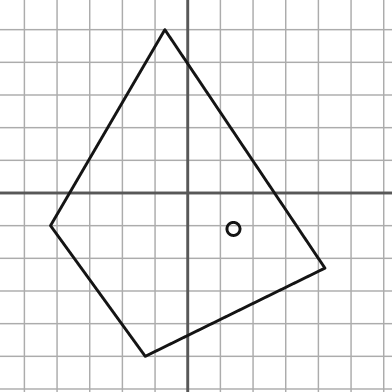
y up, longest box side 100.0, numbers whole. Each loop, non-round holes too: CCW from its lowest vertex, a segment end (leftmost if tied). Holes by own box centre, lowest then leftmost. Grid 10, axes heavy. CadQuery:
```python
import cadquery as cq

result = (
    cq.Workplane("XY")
    .moveTo(-13.0, -50.0)
    .lineTo(42.0, -23.0)
    .lineTo(-7.0, 50.0)
    .lineTo(-42.0, -10.0)
    .close()
    .moveTo(14.0, -11.0)
    .circle(2.0)
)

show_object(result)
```